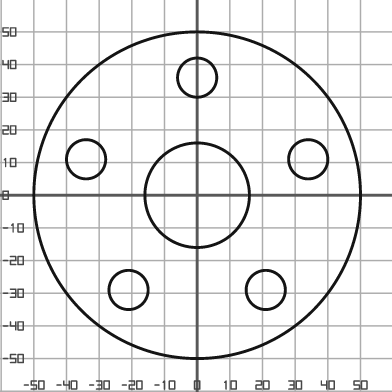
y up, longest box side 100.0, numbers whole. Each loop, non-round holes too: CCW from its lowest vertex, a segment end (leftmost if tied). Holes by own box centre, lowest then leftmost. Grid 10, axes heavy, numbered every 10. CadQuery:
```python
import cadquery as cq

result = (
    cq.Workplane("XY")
    .moveTo(0.0, 0.0)
    .circle(50.0)
    .moveTo(-21.0, -29.0)
    .circle(6.0)
    .moveTo(21.0, -29.0)
    .circle(6.0)
    .moveTo(0.0, 0.0)
    .circle(16.0)
    .moveTo(-34.0, 11.0)
    .circle(6.0)
    .moveTo(34.0, 11.0)
    .circle(6.0)
    .moveTo(0.0, 36.0)
    .circle(6.0)
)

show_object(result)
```